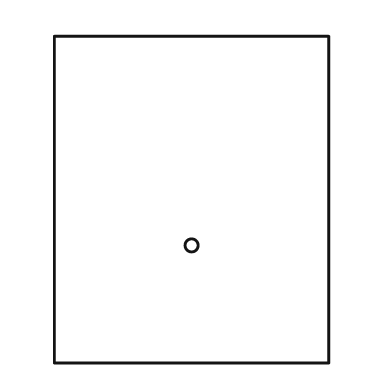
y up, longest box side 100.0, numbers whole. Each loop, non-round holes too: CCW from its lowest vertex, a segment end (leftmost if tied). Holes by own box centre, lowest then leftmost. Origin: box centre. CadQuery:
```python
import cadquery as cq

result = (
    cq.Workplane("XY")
    .moveTo(-42.0, -50.0)
    .lineTo(42.0, -50.0)
    .lineTo(42.0, 50.0)
    .lineTo(-42.0, 50.0)
    .close()
    .moveTo(0.0, -14.0)
    .circle(2.0)
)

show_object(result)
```